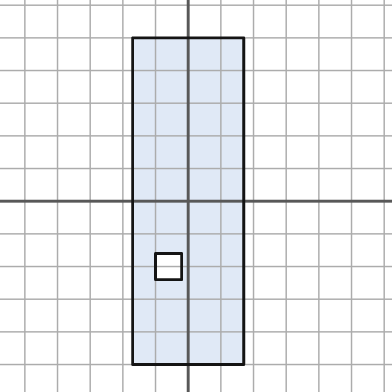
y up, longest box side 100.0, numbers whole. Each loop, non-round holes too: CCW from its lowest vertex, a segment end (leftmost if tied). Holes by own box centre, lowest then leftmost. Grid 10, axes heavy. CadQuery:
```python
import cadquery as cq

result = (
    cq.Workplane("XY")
    .moveTo(-17.0, -50.0)
    .lineTo(17.0, -50.0)
    .lineTo(17.0, 50.0)
    .lineTo(-17.0, 50.0)
    .close()
    .moveTo(-10.0, -24.0)
    .lineTo(-2.0, -24.0)
    .lineTo(-2.0, -16.0)
    .lineTo(-10.0, -16.0)
    .close()
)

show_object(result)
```